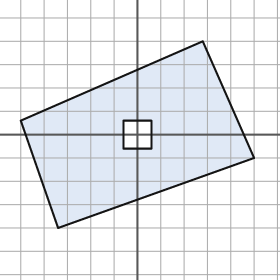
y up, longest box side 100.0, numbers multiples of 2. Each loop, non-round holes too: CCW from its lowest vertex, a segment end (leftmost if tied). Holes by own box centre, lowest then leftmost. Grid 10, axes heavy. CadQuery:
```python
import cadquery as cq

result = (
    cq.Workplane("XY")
    .moveTo(-34.0, -40.0)
    .lineTo(50.0, -10.0)
    .lineTo(28.0, 40.0)
    .lineTo(-50.0, 6.0)
    .close()
    .moveTo(-6.0, -6.0)
    .lineTo(6.0, -6.0)
    .lineTo(6.0, 6.0)
    .lineTo(-6.0, 6.0)
    .close()
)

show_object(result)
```